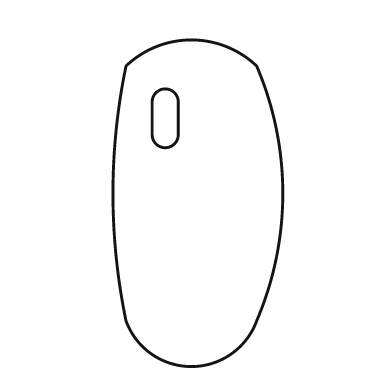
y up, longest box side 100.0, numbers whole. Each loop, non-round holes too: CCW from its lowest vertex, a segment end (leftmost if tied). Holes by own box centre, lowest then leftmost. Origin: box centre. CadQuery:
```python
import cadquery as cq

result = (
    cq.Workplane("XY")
    .moveTo(-22.0, -36.0)
    .threePointArc((-2.0, -50.0), (18.0, -36.0))
    .threePointArc((26.0, 3.0), (18.0, 42.0))
    .threePointArc((-2.0, 50.0), (-22.0, 42.0))
    .threePointArc((-26.0, 3.0), (-22.0, -36.0))
    .close()
    .moveTo(-14.0, 21.0)
    .threePointArc((-10.0, 17.0), (-6.0, 21.0))
    .lineTo(-6.0, 31.0)
    .threePointArc((-10.0, 35.0), (-14.0, 31.0))
    .close()
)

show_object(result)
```